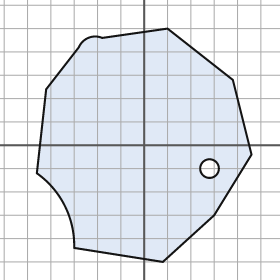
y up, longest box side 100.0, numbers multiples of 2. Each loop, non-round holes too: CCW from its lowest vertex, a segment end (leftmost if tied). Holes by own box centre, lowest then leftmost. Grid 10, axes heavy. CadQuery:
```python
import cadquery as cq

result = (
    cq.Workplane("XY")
    .moveTo(8.0, -50.0)
    .lineTo(30.0, -30.0)
    .lineTo(46.0, -4.0)
    .lineTo(38.0, 28.0)
    .lineTo(10.0, 50.0)
    .lineTo(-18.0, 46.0)
    .threePointArc((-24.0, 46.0), (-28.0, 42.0))
    .lineTo(-42.0, 24.0)
    .lineTo(-46.0, -12.0)
    .threePointArc((-34.0, -26.0), (-30.0, -44.0))
    .close()
    .moveTo(28.0, -10.0)
    .circle(4.0)
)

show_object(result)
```